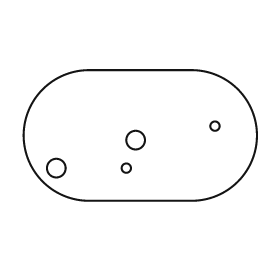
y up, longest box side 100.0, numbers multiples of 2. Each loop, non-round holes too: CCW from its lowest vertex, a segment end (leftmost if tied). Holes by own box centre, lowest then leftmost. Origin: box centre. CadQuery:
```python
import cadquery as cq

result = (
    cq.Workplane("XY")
    .moveTo(-22.0, -28.0)
    .lineTo(22.0, -28.0)
    .threePointArc((50.0, 0.0), (22.0, 28.0))
    .lineTo(-22.0, 28.0)
    .threePointArc((-50.0, 0.0), (-22.0, -28.0))
    .close()
    .moveTo(-36.0, -14.0)
    .circle(4.0)
    .moveTo(-6.0, -14.0)
    .circle(2.0)
    .moveTo(-2.0, -2.0)
    .circle(4.0)
    .moveTo(32.0, 4.0)
    .circle(2.0)
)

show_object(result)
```